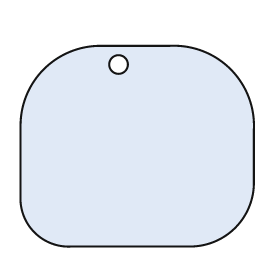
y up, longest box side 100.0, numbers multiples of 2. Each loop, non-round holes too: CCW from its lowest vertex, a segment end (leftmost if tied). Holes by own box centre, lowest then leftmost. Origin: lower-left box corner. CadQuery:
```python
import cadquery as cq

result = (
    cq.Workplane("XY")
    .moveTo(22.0, 0.0)
    .lineTo(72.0, 0.0)
    .threePointArc((92.0, 8.0), (100.0, 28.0))
    .lineTo(100.0, 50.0)
    .threePointArc((90.0, 76.0), (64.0, 86.0))
    .lineTo(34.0, 86.0)
    .threePointArc((10.0, 76.0), (0.0, 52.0))
    .lineTo(0.0, 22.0)
    .threePointArc((6.0, 6.0), (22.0, 0.0))
    .close()
    .moveTo(42.0, 78.0)
    .circle(4.0)
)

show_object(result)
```